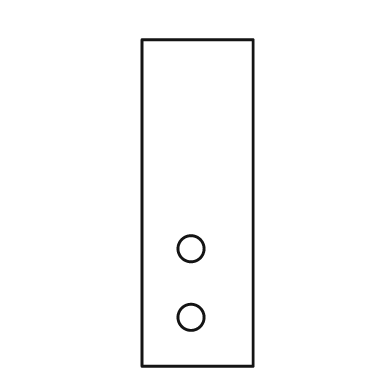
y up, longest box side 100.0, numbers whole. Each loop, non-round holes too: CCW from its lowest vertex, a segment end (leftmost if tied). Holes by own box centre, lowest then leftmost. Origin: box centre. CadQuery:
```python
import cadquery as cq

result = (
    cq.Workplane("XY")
    .moveTo(-17.0, -50.0)
    .lineTo(17.0, -50.0)
    .lineTo(17.0, 50.0)
    .lineTo(-17.0, 50.0)
    .close()
    .moveTo(-2.0, -35.0)
    .circle(4.0)
    .moveTo(-2.0, -14.0)
    .circle(4.0)
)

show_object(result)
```